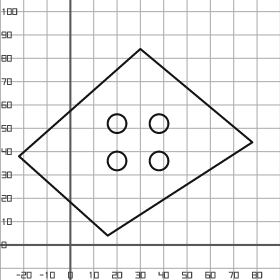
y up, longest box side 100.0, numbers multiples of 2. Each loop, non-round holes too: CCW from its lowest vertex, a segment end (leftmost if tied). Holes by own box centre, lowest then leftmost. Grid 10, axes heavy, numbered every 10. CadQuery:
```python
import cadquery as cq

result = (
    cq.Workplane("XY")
    .moveTo(16.0, 4.0)
    .lineTo(78.0, 44.0)
    .lineTo(30.0, 84.0)
    .lineTo(-22.0, 38.0)
    .close()
    .moveTo(20.0, 36.0)
    .circle(4.0)
    .moveTo(38.0, 36.0)
    .circle(4.0)
    .moveTo(20.0, 52.0)
    .circle(4.0)
    .moveTo(38.0, 52.0)
    .circle(4.0)
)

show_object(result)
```